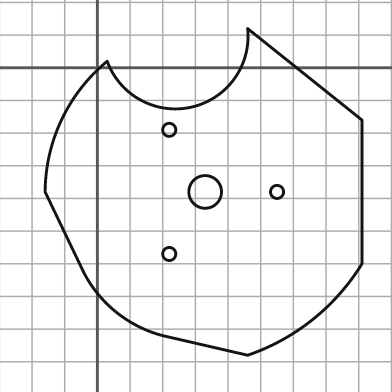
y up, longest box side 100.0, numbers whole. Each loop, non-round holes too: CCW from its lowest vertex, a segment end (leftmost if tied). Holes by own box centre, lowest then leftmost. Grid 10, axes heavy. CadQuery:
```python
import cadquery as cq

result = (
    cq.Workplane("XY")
    .moveTo(46.0, -88.0)
    .threePointArc((66.0, -77.0), (81.0, -60.0))
    .lineTo(81.0, -16.0)
    .lineTo(46.0, 12.0)
    .threePointArc((29.0, -12.0), (3.0, 2.0))
    .threePointArc((-11.0, -16.0), (-16.0, -38.0))
    .lineTo(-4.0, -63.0)
    .threePointArc((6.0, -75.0), (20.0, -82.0))
    .close()
    .moveTo(22.0, -57.0)
    .circle(2.0)
    .moveTo(33.0, -38.0)
    .circle(5.0)
    .moveTo(55.0, -38.0)
    .circle(2.0)
    .moveTo(22.0, -19.0)
    .circle(2.0)
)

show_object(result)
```